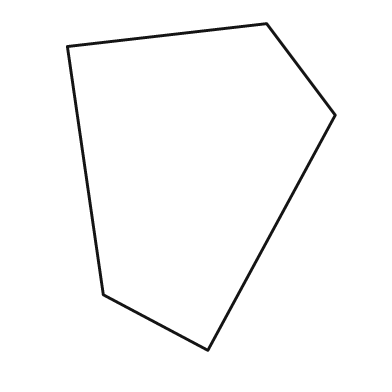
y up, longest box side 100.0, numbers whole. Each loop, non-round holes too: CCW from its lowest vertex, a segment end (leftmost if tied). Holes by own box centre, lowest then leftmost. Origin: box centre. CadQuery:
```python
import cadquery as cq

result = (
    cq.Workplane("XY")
    .moveTo(2.0, -50.0)
    .lineTo(41.0, 22.0)
    .lineTo(20.0, 50.0)
    .lineTo(-41.0, 43.0)
    .lineTo(-30.0, -33.0)
    .close()
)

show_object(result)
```